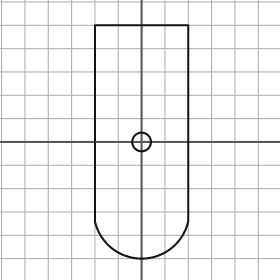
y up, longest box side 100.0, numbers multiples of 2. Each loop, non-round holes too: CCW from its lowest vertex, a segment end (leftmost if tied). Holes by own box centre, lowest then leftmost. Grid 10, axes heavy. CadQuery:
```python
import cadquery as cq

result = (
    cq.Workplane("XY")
    .moveTo(-20.0, -34.0)
    .threePointArc((0.0, -50.0), (20.0, -34.0))
    .lineTo(20.0, 50.0)
    .lineTo(-20.0, 50.0)
    .close()
    .moveTo(0.0, 0.0)
    .circle(4.0)
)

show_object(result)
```